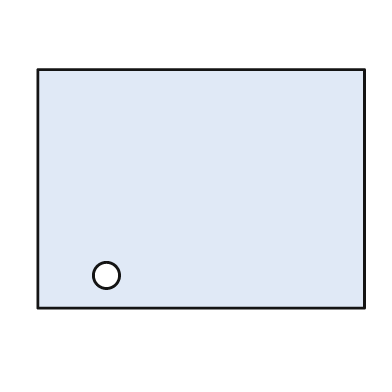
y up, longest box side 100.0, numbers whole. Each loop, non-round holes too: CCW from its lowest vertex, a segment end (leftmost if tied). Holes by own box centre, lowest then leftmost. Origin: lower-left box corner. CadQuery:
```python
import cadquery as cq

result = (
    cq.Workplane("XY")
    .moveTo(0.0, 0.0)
    .lineTo(100.0, 0.0)
    .lineTo(100.0, 73.0)
    .lineTo(0.0, 73.0)
    .close()
    .moveTo(21.0, 10.0)
    .circle(4.0)
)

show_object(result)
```